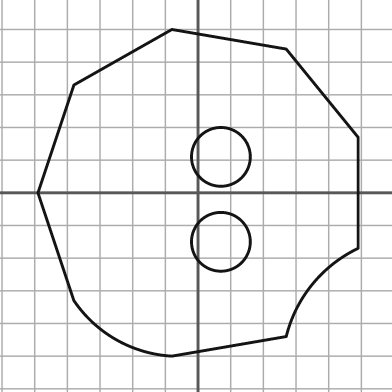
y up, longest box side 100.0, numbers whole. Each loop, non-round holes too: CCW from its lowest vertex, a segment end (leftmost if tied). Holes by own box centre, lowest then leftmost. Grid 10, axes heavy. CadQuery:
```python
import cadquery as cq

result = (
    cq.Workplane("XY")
    .moveTo(-8.0, -50.0)
    .lineTo(27.0, -44.0)
    .threePointArc((35.0, -28.0), (49.0, -17.0))
    .lineTo(49.0, 17.0)
    .lineTo(27.0, 44.0)
    .lineTo(-8.0, 50.0)
    .lineTo(-38.0, 33.0)
    .lineTo(-49.0, 0.0)
    .lineTo(-38.0, -33.0)
    .threePointArc((-25.0, -45.0), (-8.0, -50.0))
    .close()
    .moveTo(7.0, -15.0)
    .circle(9.0)
    .moveTo(7.0, 11.0)
    .circle(9.0)
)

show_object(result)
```